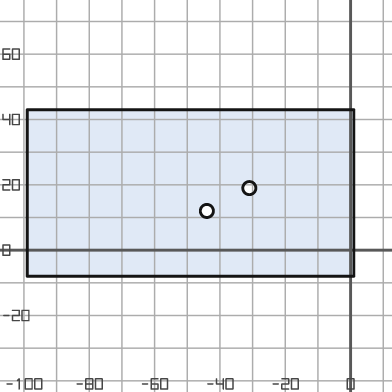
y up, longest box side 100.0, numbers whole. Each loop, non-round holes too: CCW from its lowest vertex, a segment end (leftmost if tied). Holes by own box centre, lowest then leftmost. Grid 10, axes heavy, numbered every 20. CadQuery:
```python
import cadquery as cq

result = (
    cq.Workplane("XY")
    .moveTo(-99.0, -8.0)
    .lineTo(1.0, -8.0)
    .lineTo(1.0, 43.0)
    .lineTo(-99.0, 43.0)
    .close()
    .moveTo(-44.0, 12.0)
    .circle(2.0)
    .moveTo(-31.0, 19.0)
    .circle(2.0)
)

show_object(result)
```